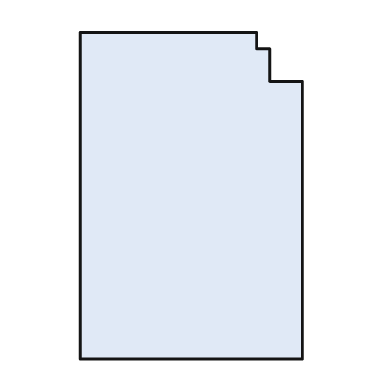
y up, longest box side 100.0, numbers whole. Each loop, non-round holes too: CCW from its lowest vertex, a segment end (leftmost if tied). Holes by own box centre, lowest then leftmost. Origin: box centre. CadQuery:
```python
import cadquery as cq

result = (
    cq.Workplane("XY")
    .moveTo(-34.0, -50.0)
    .lineTo(34.0, -50.0)
    .lineTo(34.0, 35.0)
    .lineTo(24.0, 35.0)
    .lineTo(24.0, 45.0)
    .lineTo(20.0, 45.0)
    .lineTo(20.0, 50.0)
    .lineTo(-34.0, 50.0)
    .close()
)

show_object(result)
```